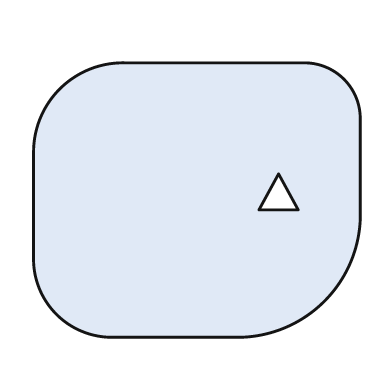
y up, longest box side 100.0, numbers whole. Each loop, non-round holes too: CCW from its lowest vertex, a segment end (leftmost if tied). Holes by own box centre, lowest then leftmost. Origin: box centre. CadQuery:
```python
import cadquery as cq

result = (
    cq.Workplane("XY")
    .moveTo(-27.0, -42.0)
    .lineTo(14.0, -42.0)
    .threePointArc((39.0, -31.0), (50.0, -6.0))
    .lineTo(50.0, 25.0)
    .threePointArc((45.0, 37.0), (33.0, 42.0))
    .lineTo(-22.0, 42.0)
    .threePointArc((-42.0, 34.0), (-50.0, 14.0))
    .lineTo(-50.0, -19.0)
    .threePointArc((-43.0, -35.0), (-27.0, -42.0))
    .close()
    .moveTo(19.0, -3.0)
    .lineTo(31.0, -3.0)
    .lineTo(25.0, 8.0)
    .close()
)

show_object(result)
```